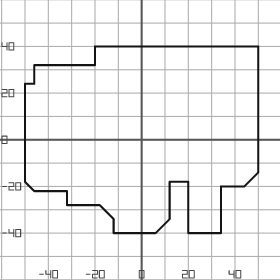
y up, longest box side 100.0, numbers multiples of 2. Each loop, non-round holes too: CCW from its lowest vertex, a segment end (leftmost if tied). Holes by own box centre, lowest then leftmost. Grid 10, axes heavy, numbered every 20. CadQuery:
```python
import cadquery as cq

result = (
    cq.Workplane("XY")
    .moveTo(-12.0, -40.0)
    .lineTo(6.0, -40.0)
    .lineTo(12.0, -34.0)
    .lineTo(12.0, -18.0)
    .lineTo(20.0, -18.0)
    .lineTo(20.0, -40.0)
    .lineTo(34.0, -40.0)
    .lineTo(34.0, -20.0)
    .lineTo(44.0, -20.0)
    .lineTo(50.0, -14.0)
    .lineTo(50.0, 40.0)
    .lineTo(-20.0, 40.0)
    .lineTo(-20.0, 32.0)
    .lineTo(-46.0, 32.0)
    .lineTo(-46.0, 24.0)
    .lineTo(-50.0, 24.0)
    .lineTo(-50.0, -18.0)
    .lineTo(-46.0, -22.0)
    .lineTo(-32.0, -22.0)
    .lineTo(-32.0, -28.0)
    .lineTo(-18.0, -28.0)
    .lineTo(-12.0, -34.0)
    .close()
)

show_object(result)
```